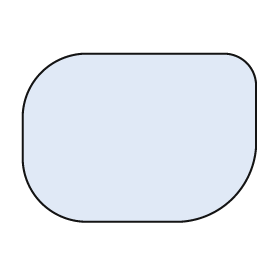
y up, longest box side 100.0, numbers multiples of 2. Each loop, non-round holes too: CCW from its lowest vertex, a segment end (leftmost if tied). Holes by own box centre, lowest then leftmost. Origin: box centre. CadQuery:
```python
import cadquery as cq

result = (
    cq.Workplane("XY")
    .moveTo(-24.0, -36.0)
    .lineTo(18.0, -36.0)
    .threePointArc((40.0, -26.0), (50.0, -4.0))
    .lineTo(50.0, 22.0)
    .threePointArc((46.0, 32.0), (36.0, 36.0))
    .lineTo(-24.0, 36.0)
    .threePointArc((-42.0, 28.0), (-50.0, 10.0))
    .lineTo(-50.0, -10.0)
    .threePointArc((-42.0, -28.0), (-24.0, -36.0))
    .close()
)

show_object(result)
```